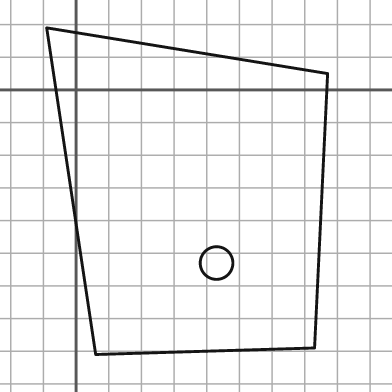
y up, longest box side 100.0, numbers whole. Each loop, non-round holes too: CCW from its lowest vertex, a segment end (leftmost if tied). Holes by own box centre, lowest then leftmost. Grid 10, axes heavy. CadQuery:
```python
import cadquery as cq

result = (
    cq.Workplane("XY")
    .moveTo(6.0, -81.0)
    .lineTo(73.0, -79.0)
    .lineTo(77.0, 5.0)
    .lineTo(-9.0, 19.0)
    .close()
    .moveTo(43.0, -53.0)
    .circle(5.0)
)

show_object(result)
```